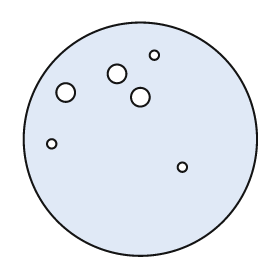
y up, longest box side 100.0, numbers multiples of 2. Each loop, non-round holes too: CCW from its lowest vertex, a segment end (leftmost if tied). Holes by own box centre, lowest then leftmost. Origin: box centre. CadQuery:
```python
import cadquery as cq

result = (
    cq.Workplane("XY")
    .moveTo(0.0, 0.0)
    .circle(50.0)
    .moveTo(18.0, -12.0)
    .circle(2.0)
    .moveTo(-38.0, -2.0)
    .circle(2.0)
    .moveTo(0.0, 18.0)
    .circle(4.0)
    .moveTo(-32.0, 20.0)
    .circle(4.0)
    .moveTo(-10.0, 28.0)
    .circle(4.0)
    .moveTo(6.0, 36.0)
    .circle(2.0)
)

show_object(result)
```